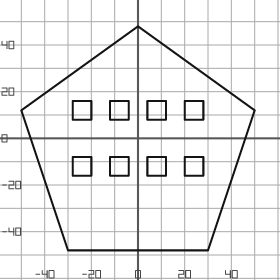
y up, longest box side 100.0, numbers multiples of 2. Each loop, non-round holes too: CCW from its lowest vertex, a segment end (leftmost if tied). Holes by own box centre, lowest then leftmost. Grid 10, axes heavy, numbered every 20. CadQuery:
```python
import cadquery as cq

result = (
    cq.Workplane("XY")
    .moveTo(-30.0, -48.0)
    .lineTo(30.0, -48.0)
    .lineTo(50.0, 12.0)
    .lineTo(0.0, 48.0)
    .lineTo(-50.0, 12.0)
    .close()
    .moveTo(-28.0, -16.0)
    .lineTo(-20.0, -16.0)
    .lineTo(-20.0, -8.0)
    .lineTo(-28.0, -8.0)
    .close()
    .moveTo(-12.0, -16.0)
    .lineTo(-4.0, -16.0)
    .lineTo(-4.0, -8.0)
    .lineTo(-12.0, -8.0)
    .close()
    .moveTo(4.0, -16.0)
    .lineTo(12.0, -16.0)
    .lineTo(12.0, -8.0)
    .lineTo(4.0, -8.0)
    .close()
    .moveTo(20.0, -16.0)
    .lineTo(28.0, -16.0)
    .lineTo(28.0, -8.0)
    .lineTo(20.0, -8.0)
    .close()
    .moveTo(-28.0, 8.0)
    .lineTo(-20.0, 8.0)
    .lineTo(-20.0, 16.0)
    .lineTo(-28.0, 16.0)
    .close()
    .moveTo(-12.0, 8.0)
    .lineTo(-4.0, 8.0)
    .lineTo(-4.0, 16.0)
    .lineTo(-12.0, 16.0)
    .close()
    .moveTo(4.0, 8.0)
    .lineTo(12.0, 8.0)
    .lineTo(12.0, 16.0)
    .lineTo(4.0, 16.0)
    .close()
    .moveTo(20.0, 8.0)
    .lineTo(28.0, 8.0)
    .lineTo(28.0, 16.0)
    .lineTo(20.0, 16.0)
    .close()
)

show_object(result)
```